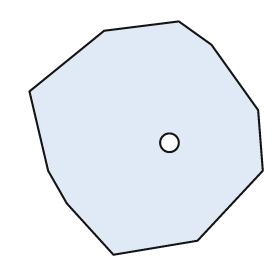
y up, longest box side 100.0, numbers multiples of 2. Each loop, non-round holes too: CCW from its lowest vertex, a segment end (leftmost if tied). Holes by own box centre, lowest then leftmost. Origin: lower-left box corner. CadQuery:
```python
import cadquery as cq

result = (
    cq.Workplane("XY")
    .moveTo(36.0, 0.0)
    .lineTo(72.0, 6.0)
    .lineTo(100.0, 36.0)
    .lineTo(98.0, 62.0)
    .lineTo(78.0, 90.0)
    .lineTo(64.0, 100.0)
    .lineTo(32.0, 96.0)
    .lineTo(0.0, 70.0)
    .lineTo(8.0, 36.0)
    .lineTo(16.0, 22.0)
    .close()
    .moveTo(60.0, 48.0)
    .circle(4.0)
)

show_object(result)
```